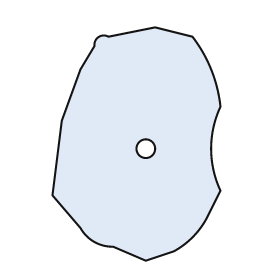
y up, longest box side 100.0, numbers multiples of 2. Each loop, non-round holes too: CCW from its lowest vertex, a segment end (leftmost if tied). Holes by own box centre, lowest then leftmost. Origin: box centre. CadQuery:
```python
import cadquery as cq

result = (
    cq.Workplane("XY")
    .moveTo(4.0, -50.0)
    .lineTo(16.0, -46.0)
    .threePointArc((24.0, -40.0), (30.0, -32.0))
    .lineTo(36.0, -20.0)
    .threePointArc((32.0, -2.0), (36.0, 16.0))
    .threePointArc((32.0, 32.0), (24.0, 46.0))
    .lineTo(8.0, 50.0)
    .lineTo(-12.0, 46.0)
    .threePointArc((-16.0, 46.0), (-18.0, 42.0))
    .lineTo(-24.0, 32.0)
    .lineTo(-32.0, 10.0)
    .lineTo(-36.0, -22.0)
    .lineTo(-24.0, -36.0)
    .threePointArc((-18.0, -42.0), (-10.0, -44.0))
    .close()
    .moveTo(4.0, -2.0)
    .circle(4.0)
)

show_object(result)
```